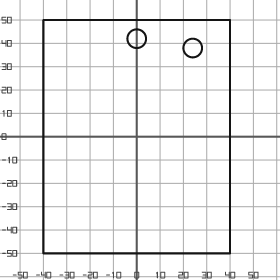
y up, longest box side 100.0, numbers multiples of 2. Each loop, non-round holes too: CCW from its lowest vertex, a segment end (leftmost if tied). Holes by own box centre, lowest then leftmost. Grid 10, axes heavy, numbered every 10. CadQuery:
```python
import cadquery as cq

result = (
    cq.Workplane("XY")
    .moveTo(-40.0, -50.0)
    .lineTo(40.0, -50.0)
    .lineTo(40.0, 50.0)
    .lineTo(-40.0, 50.0)
    .close()
    .moveTo(24.0, 38.0)
    .circle(4.0)
    .moveTo(0.0, 42.0)
    .circle(4.0)
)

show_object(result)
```